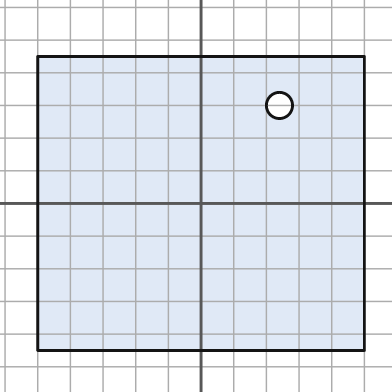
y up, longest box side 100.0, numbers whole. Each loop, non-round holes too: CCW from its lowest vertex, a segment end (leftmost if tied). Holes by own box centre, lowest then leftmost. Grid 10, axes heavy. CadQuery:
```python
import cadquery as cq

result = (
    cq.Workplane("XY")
    .moveTo(-50.0, -45.0)
    .lineTo(50.0, -45.0)
    .lineTo(50.0, 45.0)
    .lineTo(-50.0, 45.0)
    .close()
    .moveTo(24.0, 30.0)
    .circle(4.0)
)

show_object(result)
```